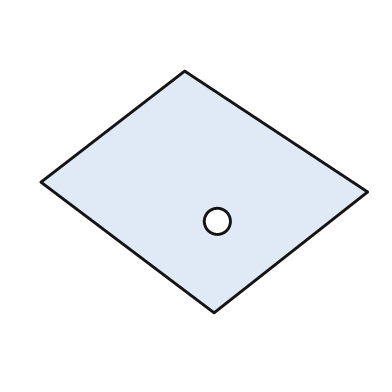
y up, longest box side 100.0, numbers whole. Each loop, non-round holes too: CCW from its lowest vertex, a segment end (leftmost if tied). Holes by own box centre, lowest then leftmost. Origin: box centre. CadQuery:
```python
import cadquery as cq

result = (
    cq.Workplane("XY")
    .moveTo(3.0, -37.0)
    .lineTo(50.0, 0.0)
    .lineTo(-6.0, 37.0)
    .lineTo(-50.0, 3.0)
    .close()
    .moveTo(4.0, -9.0)
    .circle(4.0)
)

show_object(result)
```